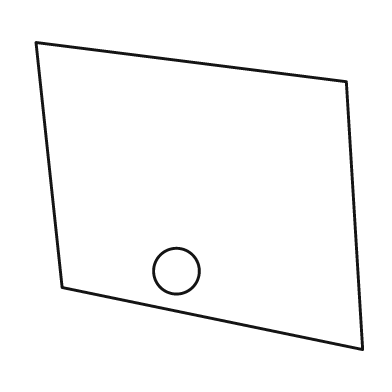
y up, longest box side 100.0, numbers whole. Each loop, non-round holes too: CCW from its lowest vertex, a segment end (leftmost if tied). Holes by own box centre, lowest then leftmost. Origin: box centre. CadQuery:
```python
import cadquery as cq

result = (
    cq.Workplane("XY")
    .moveTo(50.0, -47.0)
    .lineTo(45.0, 35.0)
    .lineTo(-50.0, 47.0)
    .lineTo(-42.0, -28.0)
    .close()
    .moveTo(-7.0, -23.0)
    .circle(7.0)
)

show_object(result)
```